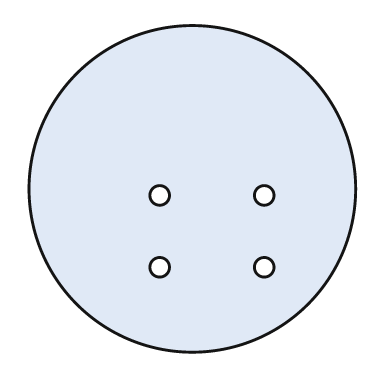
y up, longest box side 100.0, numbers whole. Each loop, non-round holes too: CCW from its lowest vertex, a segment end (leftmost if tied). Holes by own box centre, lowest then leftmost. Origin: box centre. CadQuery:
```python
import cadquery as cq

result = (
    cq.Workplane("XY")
    .moveTo(0.0, 0.0)
    .circle(50.0)
    .moveTo(-10.0, -24.0)
    .circle(3.0)
    .moveTo(22.0, -24.0)
    .circle(3.0)
    .moveTo(-10.0, -2.0)
    .circle(3.0)
    .moveTo(22.0, -2.0)
    .circle(3.0)
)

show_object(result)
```